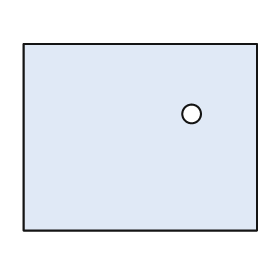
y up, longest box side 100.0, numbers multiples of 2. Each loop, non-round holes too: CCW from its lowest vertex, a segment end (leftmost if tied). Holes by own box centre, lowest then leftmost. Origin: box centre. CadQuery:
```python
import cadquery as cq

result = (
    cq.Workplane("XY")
    .moveTo(-50.0, -40.0)
    .lineTo(50.0, -40.0)
    .lineTo(50.0, 40.0)
    .lineTo(-50.0, 40.0)
    .close()
    .moveTo(22.0, 10.0)
    .circle(4.0)
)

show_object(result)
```